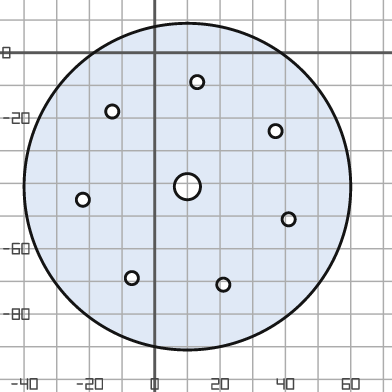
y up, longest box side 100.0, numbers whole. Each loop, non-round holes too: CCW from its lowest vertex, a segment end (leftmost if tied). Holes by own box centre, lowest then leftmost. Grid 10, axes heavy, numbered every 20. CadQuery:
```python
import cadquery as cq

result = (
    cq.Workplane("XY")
    .moveTo(10.0, -41.0)
    .circle(50.0)
    .moveTo(21.0, -71.0)
    .circle(2.0)
    .moveTo(-7.0, -69.0)
    .circle(2.0)
    .moveTo(41.0, -51.0)
    .circle(2.0)
    .moveTo(-22.0, -45.0)
    .circle(2.0)
    .moveTo(10.0, -41.0)
    .circle(4.0)
    .moveTo(37.0, -24.0)
    .circle(2.0)
    .moveTo(-13.0, -18.0)
    .circle(2.0)
    .moveTo(13.0, -9.0)
    .circle(2.0)
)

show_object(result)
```